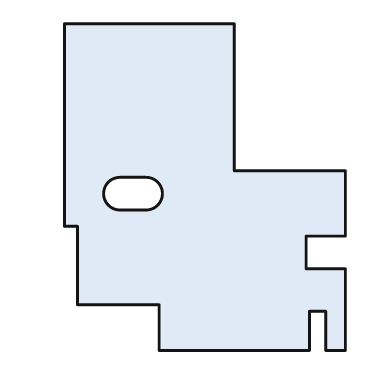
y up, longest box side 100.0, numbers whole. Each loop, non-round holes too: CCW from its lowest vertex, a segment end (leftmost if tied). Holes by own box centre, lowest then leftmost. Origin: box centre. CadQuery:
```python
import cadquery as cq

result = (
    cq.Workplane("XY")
    .moveTo(-14.0, -50.0)
    .lineTo(32.0, -50.0)
    .lineTo(32.0, -38.0)
    .lineTo(37.0, -38.0)
    .lineTo(37.0, -50.0)
    .lineTo(43.0, -50.0)
    .lineTo(43.0, -25.0)
    .lineTo(31.0, -25.0)
    .lineTo(31.0, -15.0)
    .lineTo(43.0, -15.0)
    .lineTo(43.0, 5.0)
    .lineTo(9.0, 5.0)
    .lineTo(9.0, 50.0)
    .lineTo(-43.0, 50.0)
    .lineTo(-43.0, -12.0)
    .lineTo(-39.0, -12.0)
    .lineTo(-39.0, -36.0)
    .lineTo(-14.0, -36.0)
    .close()
    .moveTo(-26.0, -7.0)
    .lineTo(-18.0, -7.0)
    .threePointArc((-13.0, -2.0), (-18.0, 3.0))
    .lineTo(-26.0, 3.0)
    .threePointArc((-31.0, -2.0), (-26.0, -7.0))
    .close()
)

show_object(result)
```